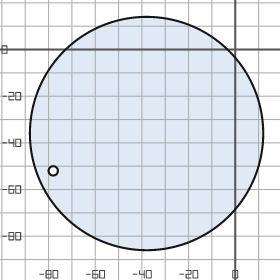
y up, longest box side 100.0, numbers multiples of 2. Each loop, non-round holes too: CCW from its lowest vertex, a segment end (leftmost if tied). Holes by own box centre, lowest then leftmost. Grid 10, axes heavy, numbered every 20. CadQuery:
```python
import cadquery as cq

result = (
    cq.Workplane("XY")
    .moveTo(-38.0, -36.0)
    .circle(50.0)
    .moveTo(-78.0, -52.0)
    .circle(2.0)
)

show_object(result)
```